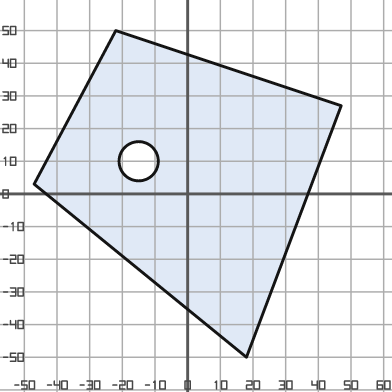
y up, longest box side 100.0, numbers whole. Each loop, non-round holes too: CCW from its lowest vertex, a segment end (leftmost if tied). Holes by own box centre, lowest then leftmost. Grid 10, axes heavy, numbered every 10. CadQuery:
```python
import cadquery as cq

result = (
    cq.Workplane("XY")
    .moveTo(18.0, -50.0)
    .lineTo(47.0, 27.0)
    .lineTo(-22.0, 50.0)
    .lineTo(-47.0, 3.0)
    .close()
    .moveTo(-15.0, 10.0)
    .circle(6.0)
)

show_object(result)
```